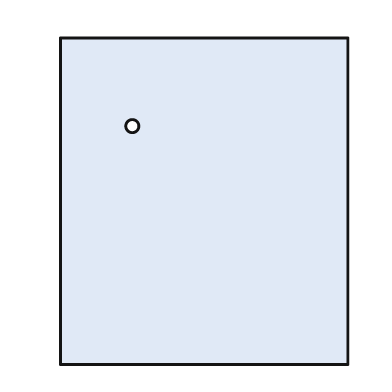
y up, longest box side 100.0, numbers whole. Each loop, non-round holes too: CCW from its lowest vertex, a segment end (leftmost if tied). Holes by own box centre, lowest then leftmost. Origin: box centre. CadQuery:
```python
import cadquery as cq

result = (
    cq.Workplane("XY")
    .moveTo(-44.0, -50.0)
    .lineTo(44.0, -50.0)
    .lineTo(44.0, 50.0)
    .lineTo(-44.0, 50.0)
    .close()
    .moveTo(-22.0, 23.0)
    .circle(2.0)
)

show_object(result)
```